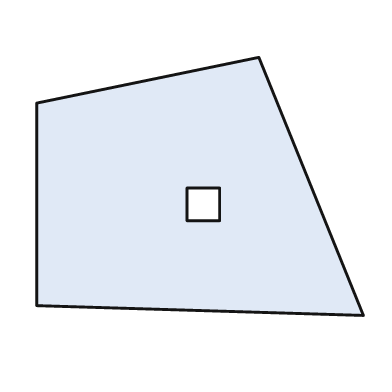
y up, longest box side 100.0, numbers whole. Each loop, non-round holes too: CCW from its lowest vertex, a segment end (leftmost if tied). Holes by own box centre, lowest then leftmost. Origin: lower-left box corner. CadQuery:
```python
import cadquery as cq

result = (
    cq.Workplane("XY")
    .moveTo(100.0, 0.0)
    .lineTo(68.0, 79.0)
    .lineTo(0.0, 65.0)
    .lineTo(0.0, 3.0)
    .close()
    .moveTo(46.0, 29.0)
    .lineTo(56.0, 29.0)
    .lineTo(56.0, 39.0)
    .lineTo(46.0, 39.0)
    .close()
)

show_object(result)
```